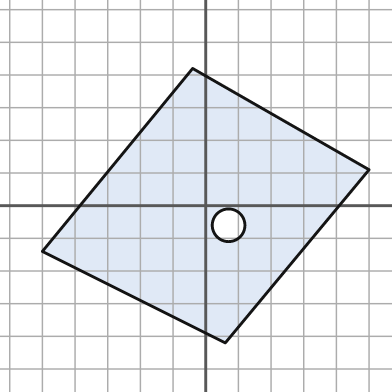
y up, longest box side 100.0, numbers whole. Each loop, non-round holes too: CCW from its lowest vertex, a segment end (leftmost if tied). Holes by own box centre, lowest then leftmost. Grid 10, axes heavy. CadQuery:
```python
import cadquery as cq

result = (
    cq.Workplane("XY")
    .moveTo(6.0, -42.0)
    .lineTo(50.0, 11.0)
    .lineTo(-4.0, 42.0)
    .lineTo(-50.0, -14.0)
    .close()
    .moveTo(7.0, -6.0)
    .circle(5.0)
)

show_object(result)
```